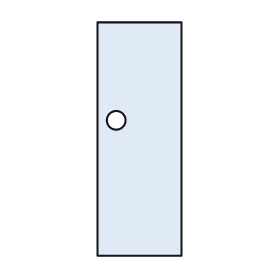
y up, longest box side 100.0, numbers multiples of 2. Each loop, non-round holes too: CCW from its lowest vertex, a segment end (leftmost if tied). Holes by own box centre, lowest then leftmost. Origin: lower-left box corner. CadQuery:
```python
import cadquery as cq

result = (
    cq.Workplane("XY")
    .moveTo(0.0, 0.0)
    .lineTo(36.0, 0.0)
    .lineTo(36.0, 100.0)
    .lineTo(0.0, 100.0)
    .close()
    .moveTo(8.0, 58.0)
    .circle(4.0)
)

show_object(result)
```